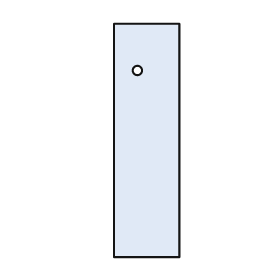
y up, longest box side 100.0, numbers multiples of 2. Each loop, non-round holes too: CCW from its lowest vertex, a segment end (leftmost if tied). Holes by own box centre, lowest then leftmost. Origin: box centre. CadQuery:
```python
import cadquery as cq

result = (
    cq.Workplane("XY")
    .moveTo(-14.0, -50.0)
    .lineTo(14.0, -50.0)
    .lineTo(14.0, 50.0)
    .lineTo(-14.0, 50.0)
    .close()
    .moveTo(-4.0, 30.0)
    .circle(2.0)
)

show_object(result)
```